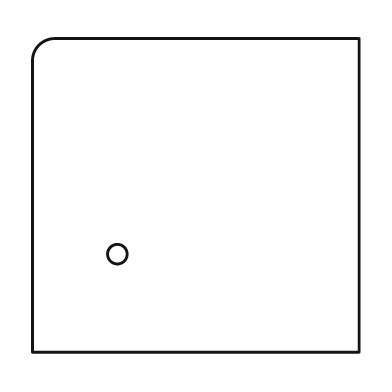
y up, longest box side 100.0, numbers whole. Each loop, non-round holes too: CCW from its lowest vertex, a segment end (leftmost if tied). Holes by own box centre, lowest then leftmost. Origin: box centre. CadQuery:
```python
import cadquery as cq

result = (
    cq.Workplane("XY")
    .moveTo(-50.0, -48.0)
    .lineTo(50.0, -48.0)
    .lineTo(50.0, 48.0)
    .lineTo(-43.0, 48.0)
    .threePointArc((-48.0, 46.0), (-50.0, 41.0))
    .close()
    .moveTo(-24.0, -18.0)
    .circle(3.0)
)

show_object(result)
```